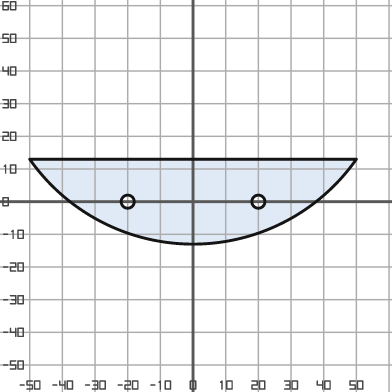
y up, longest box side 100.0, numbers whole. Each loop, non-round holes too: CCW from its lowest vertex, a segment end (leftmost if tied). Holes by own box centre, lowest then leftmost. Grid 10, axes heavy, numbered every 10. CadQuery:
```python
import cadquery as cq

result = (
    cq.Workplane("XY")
    .moveTo(-50.0, 13.0)
    .threePointArc((0.0, -13.0), (50.0, 13.0))
    .close()
    .moveTo(-20.0, 0.0)
    .circle(2.0)
    .moveTo(20.0, 0.0)
    .circle(2.0)
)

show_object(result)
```